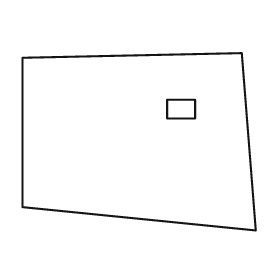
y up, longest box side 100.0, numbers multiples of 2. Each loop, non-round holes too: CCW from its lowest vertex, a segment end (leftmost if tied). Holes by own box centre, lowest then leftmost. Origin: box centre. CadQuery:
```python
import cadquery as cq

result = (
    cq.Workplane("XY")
    .moveTo(50.0, -38.0)
    .lineTo(44.0, 38.0)
    .lineTo(-50.0, 36.0)
    .lineTo(-50.0, -28.0)
    .close()
    .moveTo(12.0, 10.0)
    .lineTo(24.0, 10.0)
    .lineTo(24.0, 18.0)
    .lineTo(12.0, 18.0)
    .close()
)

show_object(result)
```